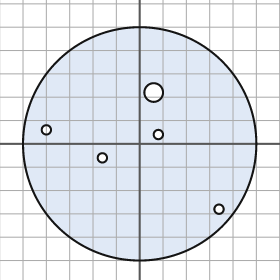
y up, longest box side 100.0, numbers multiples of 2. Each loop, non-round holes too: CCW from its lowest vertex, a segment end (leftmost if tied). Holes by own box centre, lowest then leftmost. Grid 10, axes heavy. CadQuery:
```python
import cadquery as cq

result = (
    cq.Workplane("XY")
    .moveTo(0.0, 0.0)
    .circle(50.0)
    .moveTo(34.0, -28.0)
    .circle(2.0)
    .moveTo(-16.0, -6.0)
    .circle(2.0)
    .moveTo(8.0, 4.0)
    .circle(2.0)
    .moveTo(-40.0, 6.0)
    .circle(2.0)
    .moveTo(6.0, 22.0)
    .circle(4.0)
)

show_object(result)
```